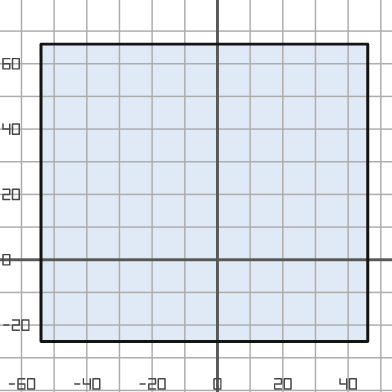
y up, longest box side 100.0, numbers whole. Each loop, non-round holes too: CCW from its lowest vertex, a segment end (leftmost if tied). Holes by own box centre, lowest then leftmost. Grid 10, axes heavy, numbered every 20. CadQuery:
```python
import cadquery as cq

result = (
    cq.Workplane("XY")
    .moveTo(-54.0, -25.0)
    .lineTo(46.0, -25.0)
    .lineTo(46.0, 66.0)
    .lineTo(-54.0, 66.0)
    .close()
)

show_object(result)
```